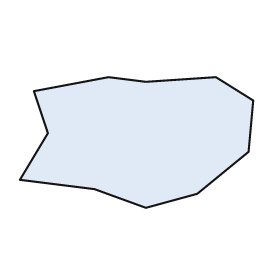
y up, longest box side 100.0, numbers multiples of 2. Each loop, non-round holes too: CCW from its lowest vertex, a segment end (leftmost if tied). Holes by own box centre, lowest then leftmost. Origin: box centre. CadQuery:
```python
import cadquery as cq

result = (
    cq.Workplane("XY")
    .moveTo(4.0, -28.0)
    .lineTo(26.0, -22.0)
    .lineTo(48.0, -4.0)
    .lineTo(50.0, 18.0)
    .lineTo(34.0, 28.0)
    .lineTo(4.0, 26.0)
    .lineTo(-12.0, 28.0)
    .lineTo(-44.0, 22.0)
    .lineTo(-38.0, 4.0)
    .lineTo(-50.0, -16.0)
    .lineTo(-18.0, -20.0)
    .close()
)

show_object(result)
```